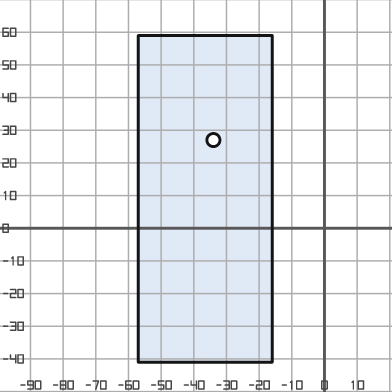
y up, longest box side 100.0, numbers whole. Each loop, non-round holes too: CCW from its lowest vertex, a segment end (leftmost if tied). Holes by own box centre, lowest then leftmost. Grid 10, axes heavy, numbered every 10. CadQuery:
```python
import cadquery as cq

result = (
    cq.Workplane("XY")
    .moveTo(-57.0, -41.0)
    .lineTo(-16.0, -41.0)
    .lineTo(-16.0, 59.0)
    .lineTo(-57.0, 59.0)
    .close()
    .moveTo(-34.0, 27.0)
    .circle(2.0)
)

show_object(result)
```